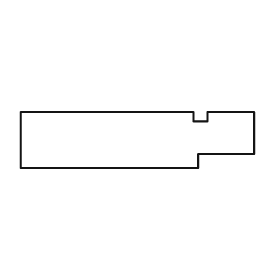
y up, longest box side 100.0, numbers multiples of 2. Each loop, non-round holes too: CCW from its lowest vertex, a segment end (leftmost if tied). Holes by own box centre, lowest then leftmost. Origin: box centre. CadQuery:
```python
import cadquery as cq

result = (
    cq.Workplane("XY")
    .moveTo(-50.0, -12.0)
    .lineTo(26.0, -12.0)
    .lineTo(26.0, -6.0)
    .lineTo(50.0, -6.0)
    .lineTo(50.0, 12.0)
    .lineTo(30.0, 12.0)
    .lineTo(30.0, 8.0)
    .lineTo(24.0, 8.0)
    .lineTo(24.0, 12.0)
    .lineTo(-50.0, 12.0)
    .close()
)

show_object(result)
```